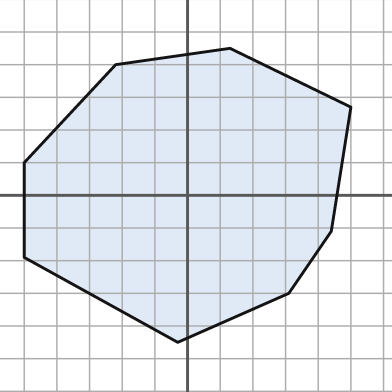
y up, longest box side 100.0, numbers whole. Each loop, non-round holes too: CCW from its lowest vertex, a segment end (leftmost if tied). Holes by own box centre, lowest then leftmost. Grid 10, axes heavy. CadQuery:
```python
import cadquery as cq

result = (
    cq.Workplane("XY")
    .moveTo(-3.0, -45.0)
    .lineTo(31.0, -30.0)
    .lineTo(44.0, -11.0)
    .lineTo(50.0, 27.0)
    .lineTo(13.0, 45.0)
    .lineTo(-22.0, 40.0)
    .lineTo(-50.0, 10.0)
    .lineTo(-50.0, -19.0)
    .close()
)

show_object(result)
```